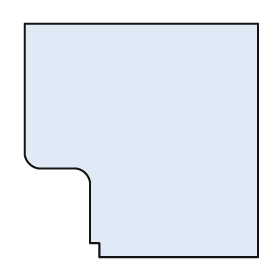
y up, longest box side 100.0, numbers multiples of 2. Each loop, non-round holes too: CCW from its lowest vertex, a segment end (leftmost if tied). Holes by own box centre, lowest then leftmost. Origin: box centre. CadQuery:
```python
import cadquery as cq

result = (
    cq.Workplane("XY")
    .moveTo(-18.0, -50.0)
    .lineTo(50.0, -50.0)
    .lineTo(50.0, 50.0)
    .lineTo(-50.0, 50.0)
    .lineTo(-50.0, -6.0)
    .threePointArc((-48.0, -10.0), (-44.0, -12.0))
    .lineTo(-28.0, -12.0)
    .threePointArc((-24.0, -14.0), (-22.0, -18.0))
    .lineTo(-22.0, -44.0)
    .lineTo(-18.0, -44.0)
    .close()
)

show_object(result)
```